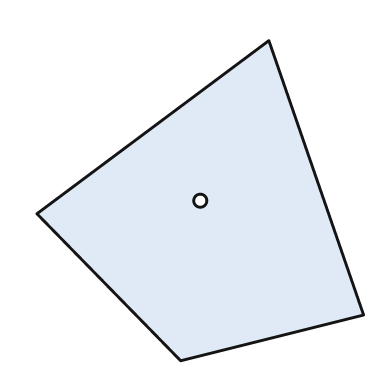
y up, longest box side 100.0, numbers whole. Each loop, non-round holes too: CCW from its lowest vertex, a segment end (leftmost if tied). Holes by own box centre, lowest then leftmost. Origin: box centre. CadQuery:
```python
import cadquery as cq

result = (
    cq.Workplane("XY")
    .moveTo(-6.0, -49.0)
    .lineTo(50.0, -35.0)
    .lineTo(21.0, 49.0)
    .lineTo(-50.0, -4.0)
    .close()
    .moveTo(0.0, 0.0)
    .circle(2.0)
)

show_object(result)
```